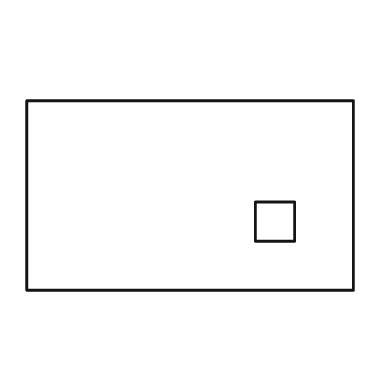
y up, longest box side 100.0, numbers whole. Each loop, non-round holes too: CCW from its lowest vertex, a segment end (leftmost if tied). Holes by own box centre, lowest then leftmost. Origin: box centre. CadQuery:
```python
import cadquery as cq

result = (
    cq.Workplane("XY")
    .moveTo(-50.0, -29.0)
    .lineTo(50.0, -29.0)
    .lineTo(50.0, 29.0)
    .lineTo(-50.0, 29.0)
    .close()
    .moveTo(20.0, -14.0)
    .lineTo(32.0, -14.0)
    .lineTo(32.0, -2.0)
    .lineTo(20.0, -2.0)
    .close()
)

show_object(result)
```